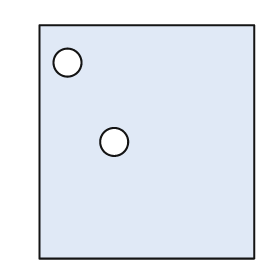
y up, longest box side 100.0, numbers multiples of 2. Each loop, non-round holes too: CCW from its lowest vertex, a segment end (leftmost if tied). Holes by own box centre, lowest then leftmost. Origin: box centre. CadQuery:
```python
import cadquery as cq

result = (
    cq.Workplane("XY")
    .moveTo(-46.0, -50.0)
    .lineTo(46.0, -50.0)
    .lineTo(46.0, 50.0)
    .lineTo(-46.0, 50.0)
    .close()
    .moveTo(-14.0, 0.0)
    .circle(6.0)
    .moveTo(-34.0, 34.0)
    .circle(6.0)
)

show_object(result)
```